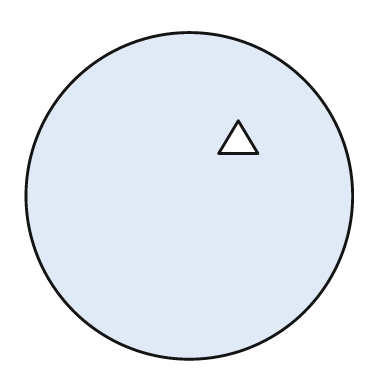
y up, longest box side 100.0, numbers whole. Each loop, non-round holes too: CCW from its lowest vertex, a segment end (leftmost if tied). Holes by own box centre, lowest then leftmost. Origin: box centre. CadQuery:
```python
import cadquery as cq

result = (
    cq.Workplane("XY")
    .moveTo(0.0, 0.0)
    .circle(50.0)
    .moveTo(9.0, 13.0)
    .lineTo(21.0, 13.0)
    .lineTo(15.0, 23.0)
    .close()
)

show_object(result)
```